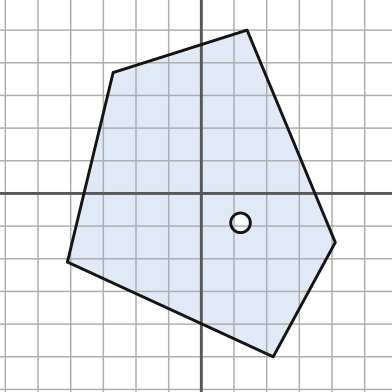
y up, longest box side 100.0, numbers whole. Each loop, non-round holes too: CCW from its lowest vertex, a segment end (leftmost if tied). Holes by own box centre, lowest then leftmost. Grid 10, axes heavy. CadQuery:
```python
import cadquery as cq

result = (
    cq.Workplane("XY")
    .moveTo(22.0, -50.0)
    .lineTo(41.0, -15.0)
    .lineTo(14.0, 50.0)
    .lineTo(-27.0, 37.0)
    .lineTo(-41.0, -21.0)
    .close()
    .moveTo(12.0, -9.0)
    .circle(3.0)
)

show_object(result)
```